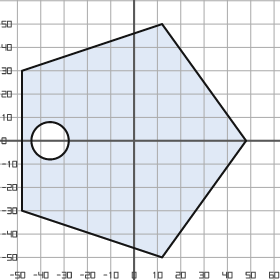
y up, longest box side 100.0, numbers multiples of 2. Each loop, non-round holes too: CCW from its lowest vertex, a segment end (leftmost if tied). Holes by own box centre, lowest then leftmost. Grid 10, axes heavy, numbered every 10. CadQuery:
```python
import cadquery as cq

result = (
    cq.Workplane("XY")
    .moveTo(12.0, -50.0)
    .lineTo(48.0, 0.0)
    .lineTo(12.0, 50.0)
    .lineTo(-48.0, 30.0)
    .lineTo(-48.0, -30.0)
    .close()
    .moveTo(-36.0, 0.0)
    .circle(8.0)
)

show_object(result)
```